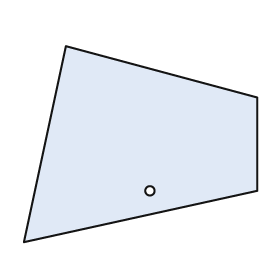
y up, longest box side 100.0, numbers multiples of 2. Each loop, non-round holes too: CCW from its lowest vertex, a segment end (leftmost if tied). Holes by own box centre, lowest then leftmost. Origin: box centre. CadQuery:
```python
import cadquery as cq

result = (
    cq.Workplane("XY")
    .moveTo(-50.0, -42.0)
    .lineTo(50.0, -20.0)
    .lineTo(50.0, 20.0)
    .lineTo(-32.0, 42.0)
    .close()
    .moveTo(4.0, -20.0)
    .circle(2.0)
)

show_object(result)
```